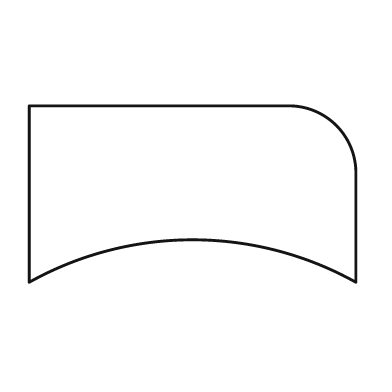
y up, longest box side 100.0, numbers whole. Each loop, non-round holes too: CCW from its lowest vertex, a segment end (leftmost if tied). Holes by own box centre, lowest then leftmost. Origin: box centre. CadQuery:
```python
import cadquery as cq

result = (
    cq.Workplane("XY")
    .moveTo(-50.0, -27.0)
    .threePointArc((0.0, -14.0), (50.0, -27.0))
    .lineTo(50.0, 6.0)
    .threePointArc((44.0, 21.0), (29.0, 27.0))
    .lineTo(-50.0, 27.0)
    .close()
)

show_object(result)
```